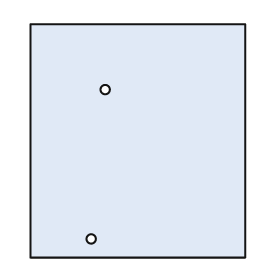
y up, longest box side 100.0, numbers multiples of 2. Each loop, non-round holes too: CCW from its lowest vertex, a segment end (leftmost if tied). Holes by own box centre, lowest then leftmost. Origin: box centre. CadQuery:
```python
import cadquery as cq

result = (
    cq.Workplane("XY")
    .moveTo(-46.0, -50.0)
    .lineTo(46.0, -50.0)
    .lineTo(46.0, 50.0)
    .lineTo(-46.0, 50.0)
    .close()
    .moveTo(-20.0, -42.0)
    .circle(2.0)
    .moveTo(-14.0, 22.0)
    .circle(2.0)
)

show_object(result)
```